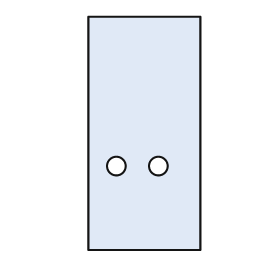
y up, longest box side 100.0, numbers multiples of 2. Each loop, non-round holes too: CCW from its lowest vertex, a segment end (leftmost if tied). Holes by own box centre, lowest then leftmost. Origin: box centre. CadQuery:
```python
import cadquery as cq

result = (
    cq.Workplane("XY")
    .moveTo(-24.0, -50.0)
    .lineTo(24.0, -50.0)
    .lineTo(24.0, 50.0)
    .lineTo(-24.0, 50.0)
    .close()
    .moveTo(-12.0, -14.0)
    .circle(4.0)
    .moveTo(6.0, -14.0)
    .circle(4.0)
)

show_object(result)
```